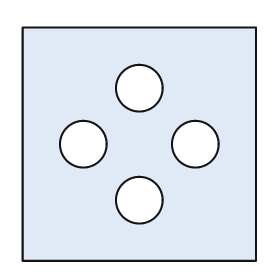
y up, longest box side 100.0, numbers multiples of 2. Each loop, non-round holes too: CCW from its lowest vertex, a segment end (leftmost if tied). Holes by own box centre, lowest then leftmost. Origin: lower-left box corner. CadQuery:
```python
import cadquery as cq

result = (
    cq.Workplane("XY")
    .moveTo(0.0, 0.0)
    .lineTo(100.0, 0.0)
    .lineTo(100.0, 100.0)
    .lineTo(0.0, 100.0)
    .close()
    .moveTo(50.0, 26.0)
    .circle(10.0)
    .moveTo(26.0, 50.0)
    .circle(10.0)
    .moveTo(74.0, 50.0)
    .circle(10.0)
    .moveTo(50.0, 74.0)
    .circle(10.0)
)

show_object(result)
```